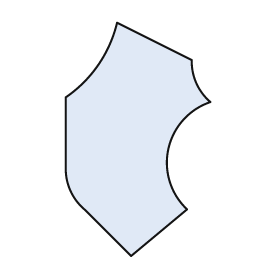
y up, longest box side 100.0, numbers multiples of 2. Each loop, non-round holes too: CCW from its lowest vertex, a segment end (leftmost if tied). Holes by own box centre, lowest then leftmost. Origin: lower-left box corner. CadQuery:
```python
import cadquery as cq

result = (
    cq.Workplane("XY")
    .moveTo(28.0, 0.0)
    .lineTo(52.0, 20.0)
    .threePointArc((44.0, 46.0), (62.0, 66.0))
    .threePointArc((56.0, 74.0), (54.0, 84.0))
    .lineTo(22.0, 100.0)
    .threePointArc((14.0, 82.0), (0.0, 68.0))
    .lineTo(0.0, 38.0)
    .threePointArc((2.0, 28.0), (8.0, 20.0))
    .close()
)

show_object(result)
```